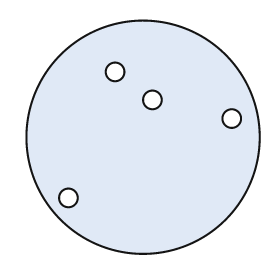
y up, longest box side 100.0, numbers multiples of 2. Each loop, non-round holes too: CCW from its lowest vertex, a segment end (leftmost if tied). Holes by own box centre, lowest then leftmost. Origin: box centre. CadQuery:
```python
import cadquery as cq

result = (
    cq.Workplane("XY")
    .moveTo(0.0, 0.0)
    .circle(50.0)
    .moveTo(-32.0, -26.0)
    .circle(4.0)
    .moveTo(38.0, 8.0)
    .circle(4.0)
    .moveTo(4.0, 16.0)
    .circle(4.0)
    .moveTo(-12.0, 28.0)
    .circle(4.0)
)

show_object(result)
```